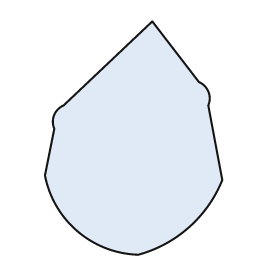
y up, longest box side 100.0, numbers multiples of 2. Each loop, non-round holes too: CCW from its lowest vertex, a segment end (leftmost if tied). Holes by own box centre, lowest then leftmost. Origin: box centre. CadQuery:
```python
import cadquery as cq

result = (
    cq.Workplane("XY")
    .moveTo(2.0, -50.0)
    .threePointArc((24.0, -38.0), (38.0, -18.0))
    .lineTo(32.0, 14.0)
    .threePointArc((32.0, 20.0), (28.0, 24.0))
    .lineTo(8.0, 50.0)
    .lineTo(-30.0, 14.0)
    .threePointArc((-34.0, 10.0), (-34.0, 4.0))
    .lineTo(-38.0, -16.0)
    .threePointArc((-24.0, -40.0), (2.0, -50.0))
    .close()
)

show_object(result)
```